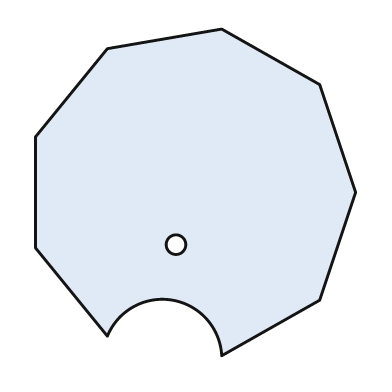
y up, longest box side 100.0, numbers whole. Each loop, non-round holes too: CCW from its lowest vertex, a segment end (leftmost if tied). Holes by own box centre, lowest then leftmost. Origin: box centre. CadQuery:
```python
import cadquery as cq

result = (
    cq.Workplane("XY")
    .moveTo(8.0, -50.0)
    .lineTo(38.0, -33.0)
    .lineTo(49.0, 0.0)
    .lineTo(38.0, 33.0)
    .lineTo(8.0, 50.0)
    .lineTo(-27.0, 44.0)
    .lineTo(-49.0, 17.0)
    .lineTo(-49.0, -17.0)
    .lineTo(-27.0, -44.0)
    .threePointArc((-7.0, -33.0), (8.0, -50.0))
    .close()
    .moveTo(-6.0, -16.0)
    .circle(3.0)
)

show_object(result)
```